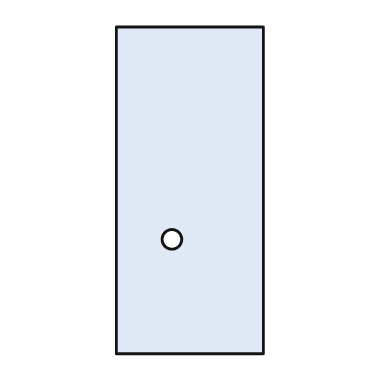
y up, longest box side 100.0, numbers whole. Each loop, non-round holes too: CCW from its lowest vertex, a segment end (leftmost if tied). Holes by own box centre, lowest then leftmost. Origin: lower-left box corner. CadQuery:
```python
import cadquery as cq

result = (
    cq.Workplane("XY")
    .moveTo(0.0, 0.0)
    .lineTo(45.0, 0.0)
    .lineTo(45.0, 100.0)
    .lineTo(0.0, 100.0)
    .close()
    .moveTo(17.0, 35.0)
    .circle(3.0)
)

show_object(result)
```